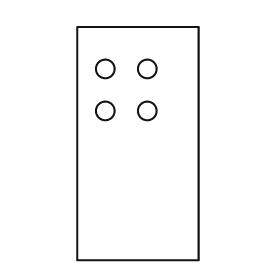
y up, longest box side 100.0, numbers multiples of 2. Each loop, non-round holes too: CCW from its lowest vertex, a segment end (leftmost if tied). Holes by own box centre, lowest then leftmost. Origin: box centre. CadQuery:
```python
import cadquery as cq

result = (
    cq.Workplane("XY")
    .moveTo(-26.0, -50.0)
    .lineTo(26.0, -50.0)
    .lineTo(26.0, 50.0)
    .lineTo(-26.0, 50.0)
    .close()
    .moveTo(-14.0, 14.0)
    .circle(4.0)
    .moveTo(4.0, 14.0)
    .circle(4.0)
    .moveTo(-14.0, 32.0)
    .circle(4.0)
    .moveTo(4.0, 32.0)
    .circle(4.0)
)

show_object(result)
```